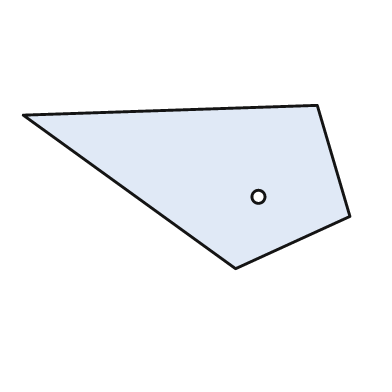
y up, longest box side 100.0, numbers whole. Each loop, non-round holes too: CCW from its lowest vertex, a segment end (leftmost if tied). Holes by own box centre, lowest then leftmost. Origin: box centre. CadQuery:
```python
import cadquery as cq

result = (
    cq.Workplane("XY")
    .moveTo(15.0, -25.0)
    .lineTo(50.0, -9.0)
    .lineTo(40.0, 25.0)
    .lineTo(-50.0, 22.0)
    .close()
    .moveTo(22.0, -3.0)
    .circle(2.0)
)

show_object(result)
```